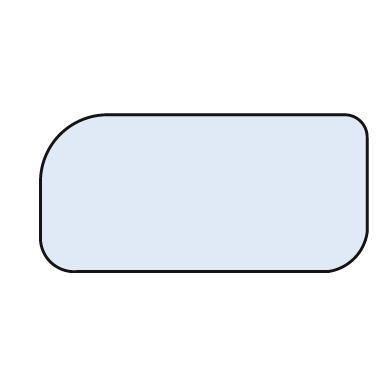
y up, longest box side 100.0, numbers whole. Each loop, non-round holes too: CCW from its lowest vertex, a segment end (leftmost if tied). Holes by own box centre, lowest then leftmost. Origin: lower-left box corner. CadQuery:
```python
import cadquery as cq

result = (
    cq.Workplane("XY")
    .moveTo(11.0, 0.0)
    .lineTo(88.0, 0.0)
    .threePointArc((96.0, 4.0), (100.0, 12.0))
    .lineTo(100.0, 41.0)
    .threePointArc((98.0, 46.0), (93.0, 48.0))
    .lineTo(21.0, 48.0)
    .threePointArc((6.0, 42.0), (0.0, 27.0))
    .lineTo(0.0, 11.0)
    .threePointArc((3.0, 3.0), (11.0, 0.0))
    .close()
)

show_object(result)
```